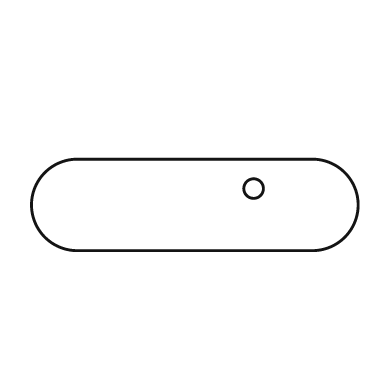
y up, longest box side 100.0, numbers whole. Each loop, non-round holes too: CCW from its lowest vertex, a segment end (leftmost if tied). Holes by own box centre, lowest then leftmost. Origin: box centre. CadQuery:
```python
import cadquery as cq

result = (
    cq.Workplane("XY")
    .moveTo(-36.0, -14.0)
    .lineTo(36.0, -14.0)
    .threePointArc((50.0, 0.0), (36.0, 14.0))
    .lineTo(-36.0, 14.0)
    .threePointArc((-50.0, 0.0), (-36.0, -14.0))
    .close()
    .moveTo(18.0, 5.0)
    .circle(3.0)
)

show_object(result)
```